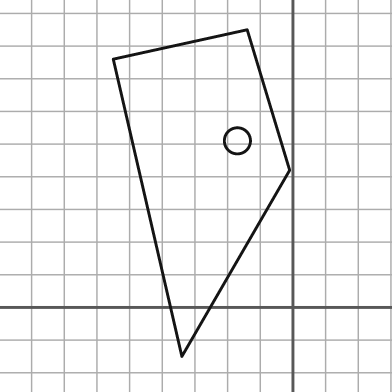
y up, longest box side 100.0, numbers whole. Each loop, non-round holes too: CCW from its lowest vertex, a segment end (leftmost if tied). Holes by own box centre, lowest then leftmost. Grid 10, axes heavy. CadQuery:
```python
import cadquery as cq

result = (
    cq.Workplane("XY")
    .moveTo(-34.0, -15.0)
    .lineTo(-1.0, 42.0)
    .lineTo(-14.0, 85.0)
    .lineTo(-55.0, 76.0)
    .close()
    .moveTo(-17.0, 51.0)
    .circle(4.0)
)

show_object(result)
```